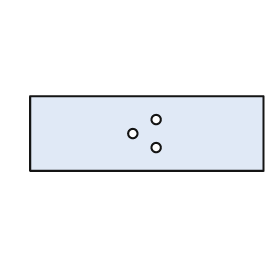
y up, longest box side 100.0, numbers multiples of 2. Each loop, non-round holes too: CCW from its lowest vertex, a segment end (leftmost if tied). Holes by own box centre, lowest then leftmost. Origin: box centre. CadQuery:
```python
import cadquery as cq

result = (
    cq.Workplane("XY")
    .moveTo(-50.0, -16.0)
    .lineTo(50.0, -16.0)
    .lineTo(50.0, 16.0)
    .lineTo(-50.0, 16.0)
    .close()
    .moveTo(4.0, -6.0)
    .circle(2.0)
    .moveTo(-6.0, 0.0)
    .circle(2.0)
    .moveTo(4.0, 6.0)
    .circle(2.0)
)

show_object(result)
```